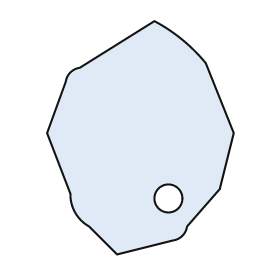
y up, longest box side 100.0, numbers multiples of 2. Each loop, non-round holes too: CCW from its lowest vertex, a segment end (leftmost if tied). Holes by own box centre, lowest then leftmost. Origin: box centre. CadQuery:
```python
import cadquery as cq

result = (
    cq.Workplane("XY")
    .moveTo(-10.0, -50.0)
    .lineTo(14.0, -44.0)
    .threePointArc((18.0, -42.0), (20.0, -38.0))
    .lineTo(34.0, -22.0)
    .lineTo(40.0, 2.0)
    .lineTo(28.0, 32.0)
    .threePointArc((18.0, 42.0), (6.0, 50.0))
    .lineTo(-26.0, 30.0)
    .threePointArc((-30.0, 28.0), (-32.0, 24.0))
    .lineTo(-40.0, 2.0)
    .lineTo(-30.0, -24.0)
    .threePointArc((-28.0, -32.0), (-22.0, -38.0))
    .close()
    .moveTo(12.0, -26.0)
    .circle(6.0)
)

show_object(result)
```